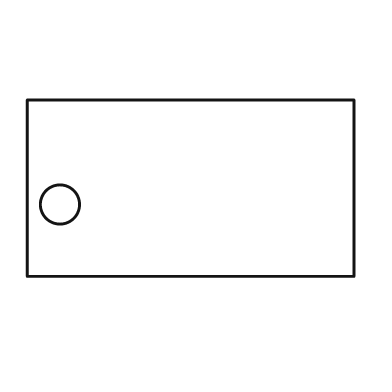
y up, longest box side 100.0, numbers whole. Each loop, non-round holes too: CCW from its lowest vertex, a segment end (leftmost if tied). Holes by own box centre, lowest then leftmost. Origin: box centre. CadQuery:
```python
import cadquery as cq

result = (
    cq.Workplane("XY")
    .moveTo(-50.0, -27.0)
    .lineTo(50.0, -27.0)
    .lineTo(50.0, 27.0)
    .lineTo(-50.0, 27.0)
    .close()
    .moveTo(-40.0, -5.0)
    .circle(6.0)
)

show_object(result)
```